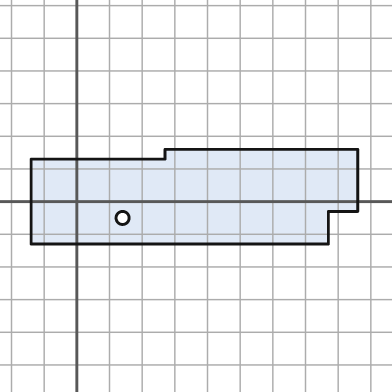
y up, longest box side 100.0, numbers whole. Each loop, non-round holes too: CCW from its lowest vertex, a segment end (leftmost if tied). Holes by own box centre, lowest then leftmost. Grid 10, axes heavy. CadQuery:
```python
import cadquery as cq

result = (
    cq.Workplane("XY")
    .moveTo(-14.0, -13.0)
    .lineTo(77.0, -13.0)
    .lineTo(77.0, -3.0)
    .lineTo(86.0, -3.0)
    .lineTo(86.0, 16.0)
    .lineTo(27.0, 16.0)
    .lineTo(27.0, 13.0)
    .lineTo(-14.0, 13.0)
    .close()
    .moveTo(14.0, -5.0)
    .circle(2.0)
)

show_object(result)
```